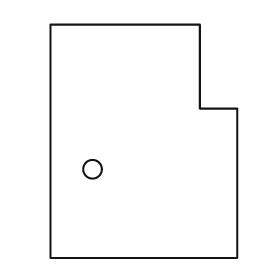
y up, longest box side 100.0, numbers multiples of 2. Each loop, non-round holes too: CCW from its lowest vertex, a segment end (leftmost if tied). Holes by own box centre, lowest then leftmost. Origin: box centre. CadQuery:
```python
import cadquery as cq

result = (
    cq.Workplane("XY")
    .moveTo(-40.0, -50.0)
    .lineTo(40.0, -50.0)
    .lineTo(40.0, 14.0)
    .lineTo(24.0, 14.0)
    .lineTo(24.0, 50.0)
    .lineTo(-40.0, 50.0)
    .close()
    .moveTo(-22.0, -12.0)
    .circle(4.0)
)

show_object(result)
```